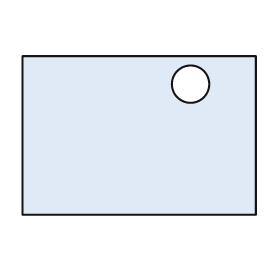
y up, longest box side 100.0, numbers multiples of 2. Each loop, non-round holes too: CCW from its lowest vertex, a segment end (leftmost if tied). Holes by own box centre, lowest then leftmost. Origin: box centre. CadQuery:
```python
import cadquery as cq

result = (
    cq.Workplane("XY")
    .moveTo(-50.0, -34.0)
    .lineTo(50.0, -34.0)
    .lineTo(50.0, 34.0)
    .lineTo(-50.0, 34.0)
    .close()
    .moveTo(22.0, 22.0)
    .circle(8.0)
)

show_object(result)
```